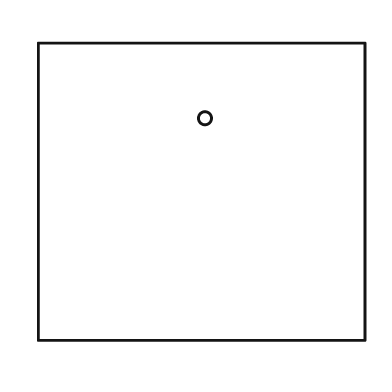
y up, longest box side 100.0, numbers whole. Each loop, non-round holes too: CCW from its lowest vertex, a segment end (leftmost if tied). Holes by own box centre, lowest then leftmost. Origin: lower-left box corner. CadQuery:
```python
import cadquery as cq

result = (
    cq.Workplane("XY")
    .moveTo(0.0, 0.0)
    .lineTo(100.0, 0.0)
    .lineTo(100.0, 91.0)
    .lineTo(0.0, 91.0)
    .close()
    .moveTo(51.0, 68.0)
    .circle(2.0)
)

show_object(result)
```